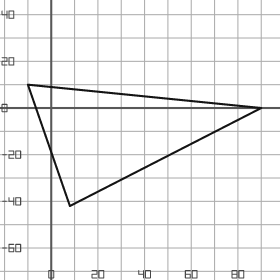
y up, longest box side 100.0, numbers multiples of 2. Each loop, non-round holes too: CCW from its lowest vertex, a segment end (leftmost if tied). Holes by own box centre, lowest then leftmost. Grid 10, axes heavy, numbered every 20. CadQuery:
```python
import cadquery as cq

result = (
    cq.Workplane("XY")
    .moveTo(8.0, -42.0)
    .lineTo(90.0, 0.0)
    .lineTo(-10.0, 10.0)
    .close()
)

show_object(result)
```